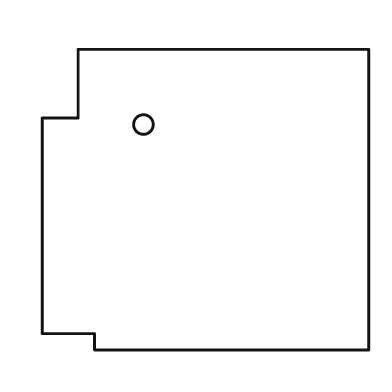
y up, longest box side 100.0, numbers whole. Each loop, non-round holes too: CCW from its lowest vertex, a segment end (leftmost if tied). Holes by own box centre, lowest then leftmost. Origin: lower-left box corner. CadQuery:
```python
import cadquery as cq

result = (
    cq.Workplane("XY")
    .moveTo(16.0, 0.0)
    .lineTo(100.0, 0.0)
    .lineTo(100.0, 92.0)
    .lineTo(11.0, 92.0)
    .lineTo(11.0, 71.0)
    .lineTo(0.0, 71.0)
    .lineTo(0.0, 5.0)
    .lineTo(16.0, 5.0)
    .close()
    .moveTo(31.0, 69.0)
    .circle(3.0)
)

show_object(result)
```